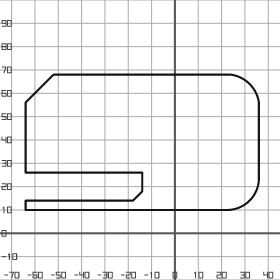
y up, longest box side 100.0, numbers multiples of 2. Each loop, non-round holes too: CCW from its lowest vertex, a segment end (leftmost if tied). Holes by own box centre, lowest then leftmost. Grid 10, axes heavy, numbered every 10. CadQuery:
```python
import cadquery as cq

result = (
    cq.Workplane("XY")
    .moveTo(-64.0, 10.0)
    .lineTo(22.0, 10.0)
    .threePointArc((32.0, 14.0), (36.0, 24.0))
    .lineTo(36.0, 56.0)
    .threePointArc((32.0, 64.0), (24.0, 68.0))
    .lineTo(-52.0, 68.0)
    .lineTo(-64.0, 56.0)
    .lineTo(-64.0, 26.0)
    .lineTo(-14.0, 26.0)
    .lineTo(-14.0, 18.0)
    .lineTo(-18.0, 14.0)
    .lineTo(-64.0, 14.0)
    .close()
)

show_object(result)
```